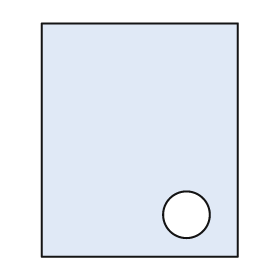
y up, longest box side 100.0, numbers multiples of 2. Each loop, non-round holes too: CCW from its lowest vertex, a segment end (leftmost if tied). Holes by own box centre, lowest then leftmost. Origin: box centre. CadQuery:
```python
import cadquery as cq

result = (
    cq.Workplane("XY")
    .moveTo(-42.0, -50.0)
    .lineTo(42.0, -50.0)
    .lineTo(42.0, 50.0)
    .lineTo(-42.0, 50.0)
    .close()
    .moveTo(20.0, -32.0)
    .circle(10.0)
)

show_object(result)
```